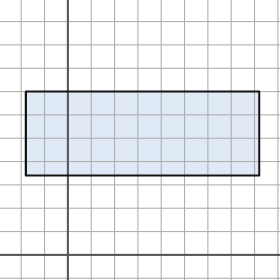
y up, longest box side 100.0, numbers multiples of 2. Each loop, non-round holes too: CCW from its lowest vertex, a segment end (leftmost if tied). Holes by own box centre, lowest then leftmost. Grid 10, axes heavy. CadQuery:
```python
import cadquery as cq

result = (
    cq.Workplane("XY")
    .moveTo(-18.0, 34.0)
    .lineTo(82.0, 34.0)
    .lineTo(82.0, 70.0)
    .lineTo(-18.0, 70.0)
    .close()
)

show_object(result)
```